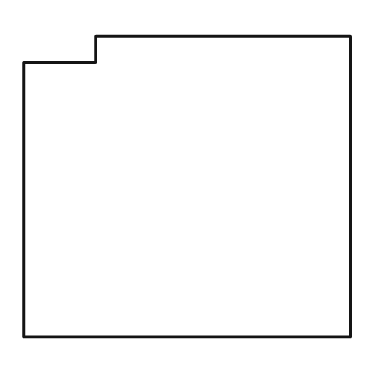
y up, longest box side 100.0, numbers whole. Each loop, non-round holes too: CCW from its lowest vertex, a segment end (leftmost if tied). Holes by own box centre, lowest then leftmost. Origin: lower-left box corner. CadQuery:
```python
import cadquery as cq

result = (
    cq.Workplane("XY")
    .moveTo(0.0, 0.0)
    .lineTo(100.0, 0.0)
    .lineTo(100.0, 92.0)
    .lineTo(22.0, 92.0)
    .lineTo(22.0, 84.0)
    .lineTo(0.0, 84.0)
    .close()
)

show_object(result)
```